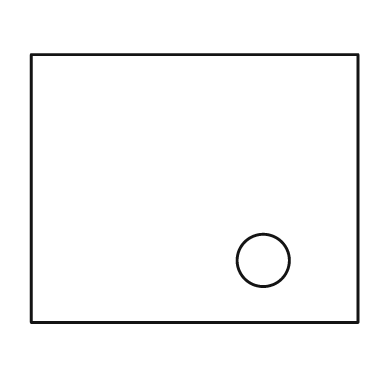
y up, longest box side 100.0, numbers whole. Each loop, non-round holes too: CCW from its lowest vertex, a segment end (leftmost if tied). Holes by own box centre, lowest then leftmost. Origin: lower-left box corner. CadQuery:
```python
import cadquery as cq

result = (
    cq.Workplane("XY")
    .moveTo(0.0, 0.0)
    .lineTo(100.0, 0.0)
    .lineTo(100.0, 82.0)
    .lineTo(0.0, 82.0)
    .close()
    .moveTo(71.0, 19.0)
    .circle(8.0)
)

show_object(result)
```